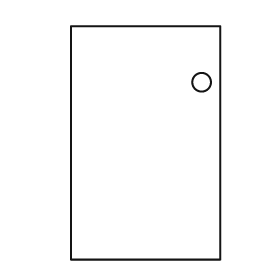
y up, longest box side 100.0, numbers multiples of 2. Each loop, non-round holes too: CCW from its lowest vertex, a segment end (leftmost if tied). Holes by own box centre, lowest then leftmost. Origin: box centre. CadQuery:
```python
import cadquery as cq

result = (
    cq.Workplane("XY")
    .moveTo(-32.0, -50.0)
    .lineTo(32.0, -50.0)
    .lineTo(32.0, 50.0)
    .lineTo(-32.0, 50.0)
    .close()
    .moveTo(24.0, 26.0)
    .circle(4.0)
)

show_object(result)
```